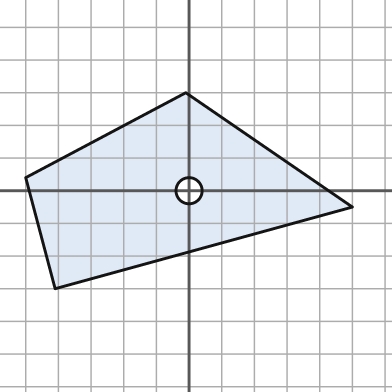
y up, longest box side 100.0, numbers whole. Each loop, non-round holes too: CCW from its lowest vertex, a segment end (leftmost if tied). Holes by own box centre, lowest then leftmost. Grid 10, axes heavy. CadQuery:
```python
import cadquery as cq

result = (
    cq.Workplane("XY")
    .moveTo(-41.0, -30.0)
    .lineTo(50.0, -5.0)
    .lineTo(-1.0, 30.0)
    .lineTo(-50.0, 4.0)
    .close()
    .moveTo(0.0, 0.0)
    .circle(4.0)
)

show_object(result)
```